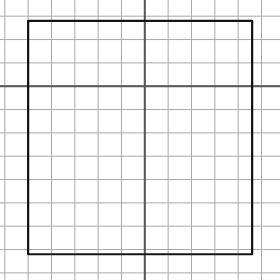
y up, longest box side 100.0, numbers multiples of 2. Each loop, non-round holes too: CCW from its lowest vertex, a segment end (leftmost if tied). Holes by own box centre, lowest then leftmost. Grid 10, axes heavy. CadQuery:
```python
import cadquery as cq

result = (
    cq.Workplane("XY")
    .moveTo(-50.0, -72.0)
    .lineTo(46.0, -72.0)
    .lineTo(46.0, 28.0)
    .lineTo(-50.0, 28.0)
    .close()
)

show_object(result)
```